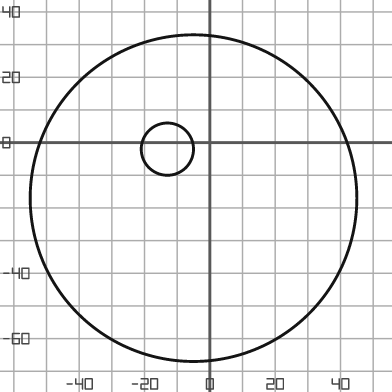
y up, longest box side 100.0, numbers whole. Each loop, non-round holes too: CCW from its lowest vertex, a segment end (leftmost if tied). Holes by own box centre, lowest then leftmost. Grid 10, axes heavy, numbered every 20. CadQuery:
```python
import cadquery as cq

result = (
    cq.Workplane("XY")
    .moveTo(-5.0, -17.0)
    .circle(50.0)
    .moveTo(-13.0, -2.0)
    .circle(8.0)
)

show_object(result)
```